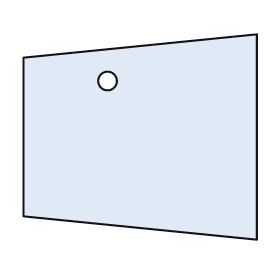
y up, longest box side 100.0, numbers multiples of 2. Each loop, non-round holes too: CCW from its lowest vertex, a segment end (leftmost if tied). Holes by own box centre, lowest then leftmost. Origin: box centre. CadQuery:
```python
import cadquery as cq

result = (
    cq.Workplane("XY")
    .moveTo(50.0, -44.0)
    .lineTo(50.0, 44.0)
    .lineTo(-50.0, 34.0)
    .lineTo(-50.0, -34.0)
    .close()
    .moveTo(-14.0, 24.0)
    .circle(4.0)
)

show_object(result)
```